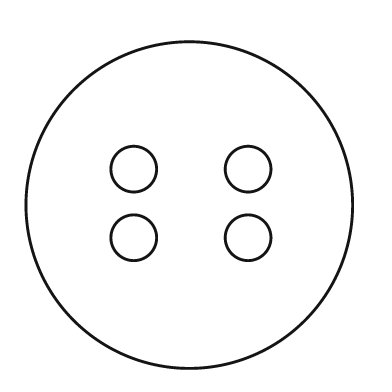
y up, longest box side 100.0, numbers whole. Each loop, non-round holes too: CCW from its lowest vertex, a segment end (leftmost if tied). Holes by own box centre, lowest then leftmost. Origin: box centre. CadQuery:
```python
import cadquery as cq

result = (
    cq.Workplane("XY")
    .moveTo(0.0, 0.0)
    .circle(50.0)
    .moveTo(-17.0, -10.0)
    .circle(7.0)
    .moveTo(18.0, -10.0)
    .circle(7.0)
    .moveTo(-17.0, 11.0)
    .circle(7.0)
    .moveTo(18.0, 11.0)
    .circle(7.0)
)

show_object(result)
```